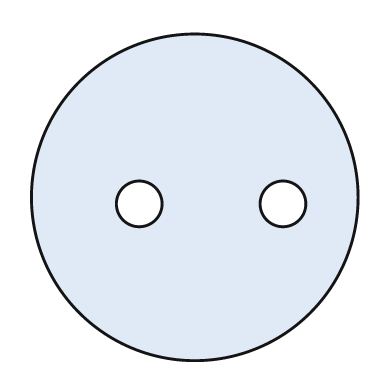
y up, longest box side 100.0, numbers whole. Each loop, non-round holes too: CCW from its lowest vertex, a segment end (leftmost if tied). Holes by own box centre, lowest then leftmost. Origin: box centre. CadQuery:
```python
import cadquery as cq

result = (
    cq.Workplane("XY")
    .moveTo(0.0, 0.0)
    .circle(50.0)
    .moveTo(-17.0, -2.0)
    .circle(7.0)
    .moveTo(27.0, -2.0)
    .circle(7.0)
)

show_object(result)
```